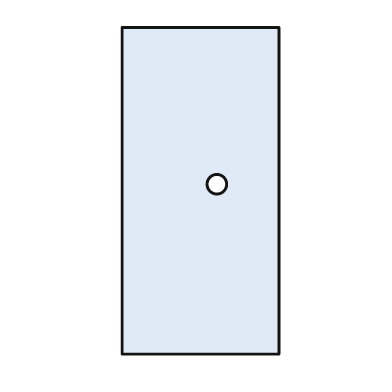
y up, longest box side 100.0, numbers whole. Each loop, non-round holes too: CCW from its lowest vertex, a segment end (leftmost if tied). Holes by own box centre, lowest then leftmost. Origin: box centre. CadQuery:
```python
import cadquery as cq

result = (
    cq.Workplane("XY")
    .moveTo(-24.0, -50.0)
    .lineTo(24.0, -50.0)
    .lineTo(24.0, 50.0)
    .lineTo(-24.0, 50.0)
    .close()
    .moveTo(5.0, 2.0)
    .circle(3.0)
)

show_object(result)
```